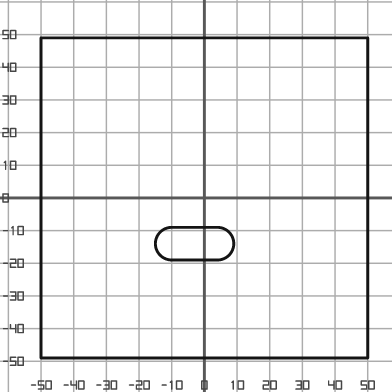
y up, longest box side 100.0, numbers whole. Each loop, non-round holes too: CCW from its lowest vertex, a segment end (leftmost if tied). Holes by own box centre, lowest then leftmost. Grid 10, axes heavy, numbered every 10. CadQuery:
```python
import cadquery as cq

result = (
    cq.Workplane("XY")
    .moveTo(-50.0, -49.0)
    .lineTo(50.0, -49.0)
    .lineTo(50.0, 49.0)
    .lineTo(-50.0, 49.0)
    .close()
    .moveTo(-10.0, -19.0)
    .lineTo(4.0, -19.0)
    .threePointArc((9.0, -14.0), (4.0, -9.0))
    .lineTo(-10.0, -9.0)
    .threePointArc((-15.0, -14.0), (-10.0, -19.0))
    .close()
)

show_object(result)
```